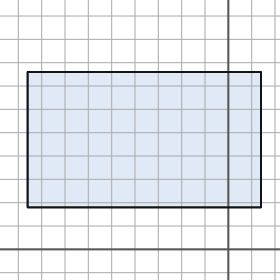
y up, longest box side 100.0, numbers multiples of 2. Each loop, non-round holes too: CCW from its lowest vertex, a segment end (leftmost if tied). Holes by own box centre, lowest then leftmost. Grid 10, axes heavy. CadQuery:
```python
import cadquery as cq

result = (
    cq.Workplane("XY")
    .moveTo(-86.0, 18.0)
    .lineTo(14.0, 18.0)
    .lineTo(14.0, 76.0)
    .lineTo(-86.0, 76.0)
    .close()
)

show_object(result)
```